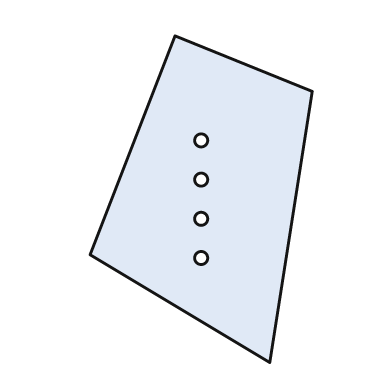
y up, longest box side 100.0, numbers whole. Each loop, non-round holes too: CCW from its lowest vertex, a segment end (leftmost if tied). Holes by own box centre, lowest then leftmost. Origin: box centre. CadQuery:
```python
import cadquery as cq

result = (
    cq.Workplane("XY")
    .moveTo(21.0, -50.0)
    .lineTo(34.0, 33.0)
    .lineTo(-8.0, 50.0)
    .lineTo(-34.0, -17.0)
    .close()
    .moveTo(0.0, -18.0)
    .circle(2.0)
    .moveTo(0.0, -6.0)
    .circle(2.0)
    .moveTo(0.0, 6.0)
    .circle(2.0)
    .moveTo(0.0, 18.0)
    .circle(2.0)
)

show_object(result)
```